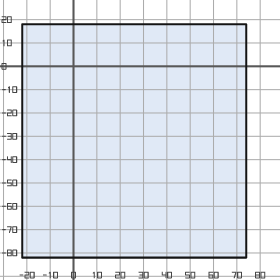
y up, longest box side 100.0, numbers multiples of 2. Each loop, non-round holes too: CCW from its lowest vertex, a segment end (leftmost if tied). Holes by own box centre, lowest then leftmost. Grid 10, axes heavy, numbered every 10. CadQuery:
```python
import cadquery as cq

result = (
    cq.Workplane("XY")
    .moveTo(-22.0, -82.0)
    .lineTo(74.0, -82.0)
    .lineTo(74.0, 18.0)
    .lineTo(-22.0, 18.0)
    .close()
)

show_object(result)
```